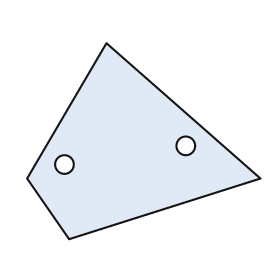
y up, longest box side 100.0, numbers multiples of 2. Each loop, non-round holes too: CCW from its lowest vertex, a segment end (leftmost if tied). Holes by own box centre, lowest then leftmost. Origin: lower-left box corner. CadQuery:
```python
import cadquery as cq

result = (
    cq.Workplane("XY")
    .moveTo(18.0, 0.0)
    .lineTo(100.0, 26.0)
    .lineTo(34.0, 84.0)
    .lineTo(0.0, 26.0)
    .close()
    .moveTo(16.0, 32.0)
    .circle(4.0)
    .moveTo(68.0, 40.0)
    .circle(4.0)
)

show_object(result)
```